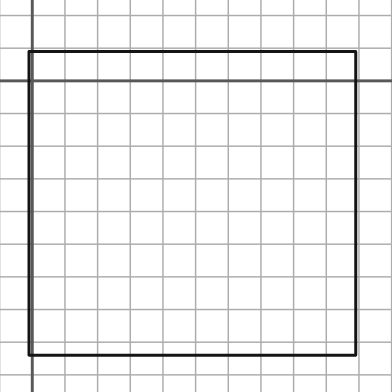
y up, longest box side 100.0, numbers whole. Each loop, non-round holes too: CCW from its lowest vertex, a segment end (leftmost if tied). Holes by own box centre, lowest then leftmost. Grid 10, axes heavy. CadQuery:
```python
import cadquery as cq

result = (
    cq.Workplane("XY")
    .moveTo(-1.0, -84.0)
    .lineTo(99.0, -84.0)
    .lineTo(99.0, 9.0)
    .lineTo(-1.0, 9.0)
    .close()
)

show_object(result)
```